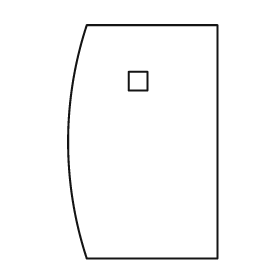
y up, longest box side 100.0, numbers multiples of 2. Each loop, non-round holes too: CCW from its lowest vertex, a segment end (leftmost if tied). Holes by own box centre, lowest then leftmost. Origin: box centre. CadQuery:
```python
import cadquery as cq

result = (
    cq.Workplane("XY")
    .moveTo(-24.0, -50.0)
    .lineTo(32.0, -50.0)
    .lineTo(32.0, 50.0)
    .lineTo(-24.0, 50.0)
    .threePointArc((-32.0, 0.0), (-24.0, -50.0))
    .close()
    .moveTo(-6.0, 22.0)
    .lineTo(2.0, 22.0)
    .lineTo(2.0, 30.0)
    .lineTo(-6.0, 30.0)
    .close()
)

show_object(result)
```